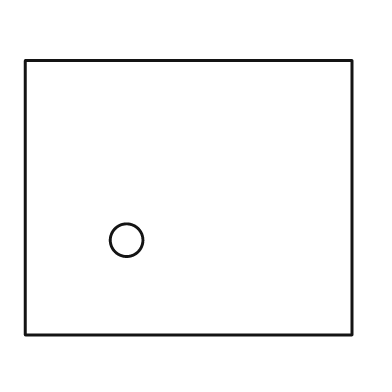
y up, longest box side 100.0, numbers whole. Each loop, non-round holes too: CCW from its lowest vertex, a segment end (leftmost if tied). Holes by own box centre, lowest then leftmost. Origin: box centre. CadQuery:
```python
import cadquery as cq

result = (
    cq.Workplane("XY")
    .moveTo(-50.0, -42.0)
    .lineTo(50.0, -42.0)
    .lineTo(50.0, 42.0)
    .lineTo(-50.0, 42.0)
    .close()
    .moveTo(-19.0, -13.0)
    .circle(5.0)
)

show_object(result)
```